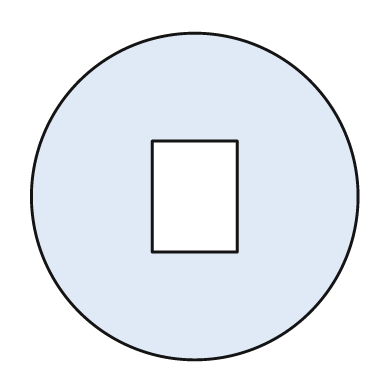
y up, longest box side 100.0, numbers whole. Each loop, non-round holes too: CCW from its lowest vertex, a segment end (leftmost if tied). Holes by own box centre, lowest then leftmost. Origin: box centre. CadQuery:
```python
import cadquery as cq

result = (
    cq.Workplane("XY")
    .moveTo(0.0, 0.0)
    .circle(50.0)
    .moveTo(-13.0, -17.0)
    .lineTo(13.0, -17.0)
    .lineTo(13.0, 17.0)
    .lineTo(-13.0, 17.0)
    .close()
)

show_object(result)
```